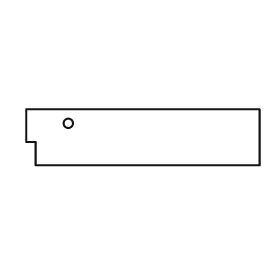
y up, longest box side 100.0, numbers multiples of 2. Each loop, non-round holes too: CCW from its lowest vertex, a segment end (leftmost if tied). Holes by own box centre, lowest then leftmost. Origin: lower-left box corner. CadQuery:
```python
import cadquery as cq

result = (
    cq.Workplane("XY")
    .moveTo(4.0, 0.0)
    .lineTo(100.0, 0.0)
    .lineTo(100.0, 24.0)
    .lineTo(0.0, 24.0)
    .lineTo(0.0, 10.0)
    .lineTo(4.0, 10.0)
    .close()
    .moveTo(18.0, 18.0)
    .circle(2.0)
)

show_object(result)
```